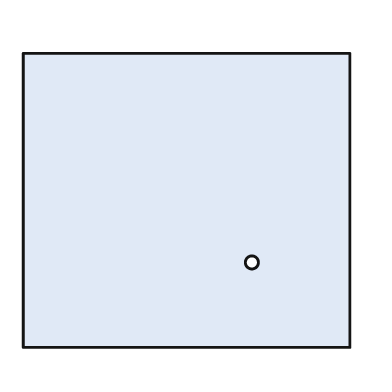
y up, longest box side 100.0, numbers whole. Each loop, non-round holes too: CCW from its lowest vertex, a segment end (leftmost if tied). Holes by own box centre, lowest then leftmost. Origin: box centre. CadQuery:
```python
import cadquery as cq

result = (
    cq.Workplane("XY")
    .moveTo(-50.0, -45.0)
    .lineTo(50.0, -45.0)
    .lineTo(50.0, 45.0)
    .lineTo(-50.0, 45.0)
    .close()
    .moveTo(20.0, -19.0)
    .circle(2.0)
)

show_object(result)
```